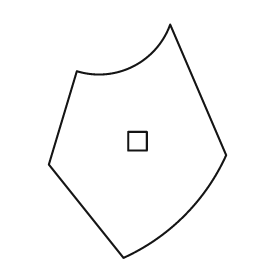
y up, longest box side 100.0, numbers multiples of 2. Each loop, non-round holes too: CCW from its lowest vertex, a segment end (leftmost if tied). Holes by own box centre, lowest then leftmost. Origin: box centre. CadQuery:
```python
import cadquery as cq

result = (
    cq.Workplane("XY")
    .moveTo(-6.0, -50.0)
    .threePointArc((20.0, -32.0), (38.0, -6.0))
    .lineTo(14.0, 50.0)
    .threePointArc((-2.0, 32.0), (-26.0, 30.0))
    .lineTo(-38.0, -10.0)
    .close()
    .moveTo(-4.0, -4.0)
    .lineTo(4.0, -4.0)
    .lineTo(4.0, 4.0)
    .lineTo(-4.0, 4.0)
    .close()
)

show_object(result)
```